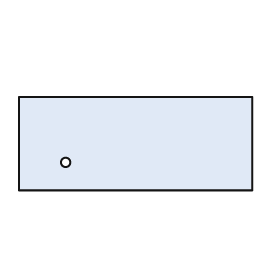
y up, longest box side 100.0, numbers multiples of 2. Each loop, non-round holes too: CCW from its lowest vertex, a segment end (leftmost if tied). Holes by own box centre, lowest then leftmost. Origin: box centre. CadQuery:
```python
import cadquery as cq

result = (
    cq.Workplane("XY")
    .moveTo(-50.0, -20.0)
    .lineTo(50.0, -20.0)
    .lineTo(50.0, 20.0)
    .lineTo(-50.0, 20.0)
    .close()
    .moveTo(-30.0, -8.0)
    .circle(2.0)
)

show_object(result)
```